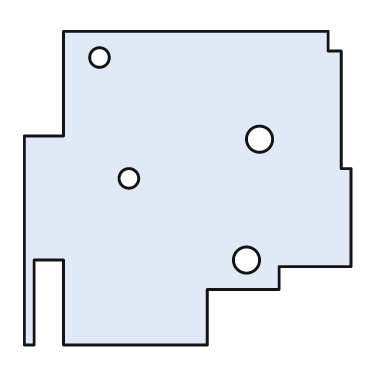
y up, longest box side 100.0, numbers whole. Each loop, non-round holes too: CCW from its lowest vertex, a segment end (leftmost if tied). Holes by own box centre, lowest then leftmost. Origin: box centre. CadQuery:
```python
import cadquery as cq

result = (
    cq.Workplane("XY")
    .moveTo(-50.0, -48.0)
    .lineTo(-47.0, -48.0)
    .lineTo(-47.0, -22.0)
    .lineTo(-38.0, -22.0)
    .lineTo(-38.0, -48.0)
    .lineTo(6.0, -48.0)
    .lineTo(6.0, -31.0)
    .lineTo(28.0, -31.0)
    .lineTo(28.0, -24.0)
    .lineTo(50.0, -24.0)
    .lineTo(50.0, 6.0)
    .lineTo(47.0, 6.0)
    .lineTo(47.0, 42.0)
    .lineTo(43.0, 42.0)
    .lineTo(43.0, 48.0)
    .lineTo(-38.0, 48.0)
    .lineTo(-38.0, 16.0)
    .lineTo(-50.0, 16.0)
    .close()
    .moveTo(18.0, -22.0)
    .circle(4.0)
    .moveTo(-18.0, 3.0)
    .circle(3.0)
    .moveTo(22.0, 15.0)
    .circle(4.0)
    .moveTo(-27.0, 40.0)
    .circle(3.0)
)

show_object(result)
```